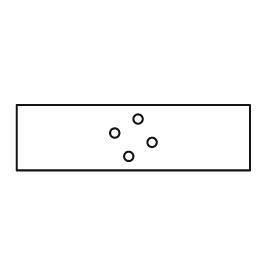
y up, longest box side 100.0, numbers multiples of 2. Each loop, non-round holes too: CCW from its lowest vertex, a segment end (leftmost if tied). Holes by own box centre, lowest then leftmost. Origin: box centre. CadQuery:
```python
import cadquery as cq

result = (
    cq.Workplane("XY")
    .moveTo(-50.0, -14.0)
    .lineTo(50.0, -14.0)
    .lineTo(50.0, 14.0)
    .lineTo(-50.0, 14.0)
    .close()
    .moveTo(-2.0, -8.0)
    .circle(2.0)
    .moveTo(8.0, -2.0)
    .circle(2.0)
    .moveTo(-8.0, 2.0)
    .circle(2.0)
    .moveTo(2.0, 8.0)
    .circle(2.0)
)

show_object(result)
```